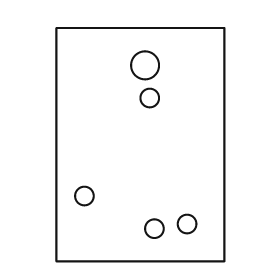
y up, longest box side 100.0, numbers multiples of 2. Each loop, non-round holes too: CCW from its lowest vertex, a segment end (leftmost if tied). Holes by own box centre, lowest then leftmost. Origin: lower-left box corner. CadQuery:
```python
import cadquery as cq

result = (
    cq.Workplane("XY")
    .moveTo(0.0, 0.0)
    .lineTo(72.0, 0.0)
    .lineTo(72.0, 100.0)
    .lineTo(0.0, 100.0)
    .close()
    .moveTo(42.0, 14.0)
    .circle(4.0)
    .moveTo(56.0, 16.0)
    .circle(4.0)
    .moveTo(12.0, 28.0)
    .circle(4.0)
    .moveTo(40.0, 70.0)
    .circle(4.0)
    .moveTo(38.0, 84.0)
    .circle(6.0)
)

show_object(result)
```